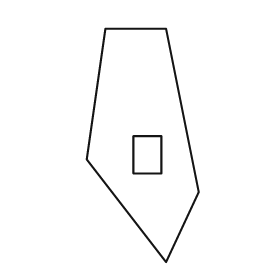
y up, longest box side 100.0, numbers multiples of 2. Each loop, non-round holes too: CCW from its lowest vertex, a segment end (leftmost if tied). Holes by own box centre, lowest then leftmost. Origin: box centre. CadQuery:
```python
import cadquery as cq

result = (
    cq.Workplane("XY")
    .moveTo(10.0, -50.0)
    .lineTo(24.0, -20.0)
    .lineTo(10.0, 50.0)
    .lineTo(-16.0, 50.0)
    .lineTo(-24.0, -6.0)
    .close()
    .moveTo(-4.0, -12.0)
    .lineTo(8.0, -12.0)
    .lineTo(8.0, 4.0)
    .lineTo(-4.0, 4.0)
    .close()
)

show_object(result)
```